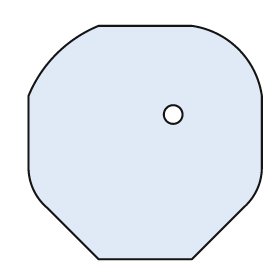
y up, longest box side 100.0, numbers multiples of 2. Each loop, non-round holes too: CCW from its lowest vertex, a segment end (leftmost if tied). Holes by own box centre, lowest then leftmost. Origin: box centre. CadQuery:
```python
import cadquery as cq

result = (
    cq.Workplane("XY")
    .moveTo(-20.0, -50.0)
    .lineTo(20.0, -50.0)
    .lineTo(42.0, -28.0)
    .threePointArc((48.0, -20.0), (50.0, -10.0))
    .lineTo(50.0, 20.0)
    .threePointArc((40.0, 40.0), (20.0, 50.0))
    .lineTo(-20.0, 50.0)
    .threePointArc((-38.0, 38.0), (-50.0, 20.0))
    .lineTo(-50.0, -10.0)
    .threePointArc((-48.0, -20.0), (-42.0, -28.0))
    .close()
    .moveTo(12.0, 12.0)
    .circle(4.0)
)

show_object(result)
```